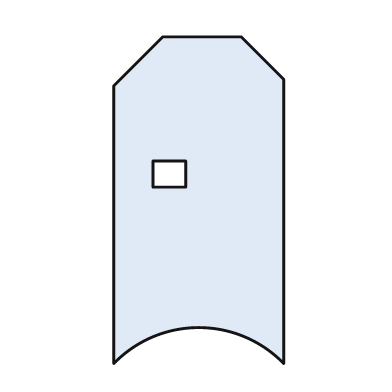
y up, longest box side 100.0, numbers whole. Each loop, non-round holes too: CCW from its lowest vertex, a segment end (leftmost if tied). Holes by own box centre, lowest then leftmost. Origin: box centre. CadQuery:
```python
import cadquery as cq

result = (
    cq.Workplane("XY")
    .moveTo(-26.0, -50.0)
    .threePointArc((0.0, -39.0), (26.0, -50.0))
    .lineTo(26.0, 37.0)
    .lineTo(13.0, 50.0)
    .lineTo(-11.0, 50.0)
    .lineTo(-26.0, 35.0)
    .close()
    .moveTo(-14.0, 4.0)
    .lineTo(-4.0, 4.0)
    .lineTo(-4.0, 12.0)
    .lineTo(-14.0, 12.0)
    .close()
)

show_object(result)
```